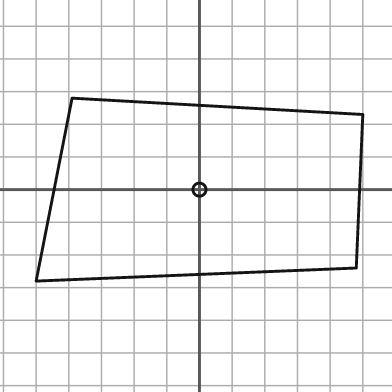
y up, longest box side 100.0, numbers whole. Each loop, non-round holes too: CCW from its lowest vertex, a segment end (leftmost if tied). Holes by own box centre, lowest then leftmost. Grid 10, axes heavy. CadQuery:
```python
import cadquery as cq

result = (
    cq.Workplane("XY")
    .moveTo(-50.0, -28.0)
    .lineTo(48.0, -24.0)
    .lineTo(50.0, 23.0)
    .lineTo(-39.0, 28.0)
    .close()
    .moveTo(0.0, 0.0)
    .circle(2.0)
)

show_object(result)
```